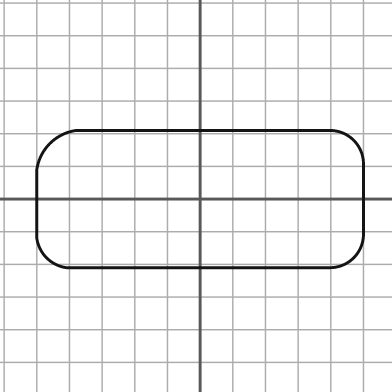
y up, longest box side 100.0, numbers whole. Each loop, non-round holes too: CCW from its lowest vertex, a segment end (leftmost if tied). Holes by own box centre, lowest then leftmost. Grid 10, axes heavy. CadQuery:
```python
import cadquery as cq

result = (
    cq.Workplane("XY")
    .moveTo(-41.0, -21.0)
    .lineTo(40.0, -21.0)
    .threePointArc((47.0, -18.0), (50.0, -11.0))
    .lineTo(50.0, 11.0)
    .threePointArc((47.0, 18.0), (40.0, 21.0))
    .lineTo(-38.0, 21.0)
    .threePointArc((-46.0, 17.0), (-50.0, 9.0))
    .lineTo(-50.0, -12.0)
    .threePointArc((-47.0, -18.0), (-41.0, -21.0))
    .close()
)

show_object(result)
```